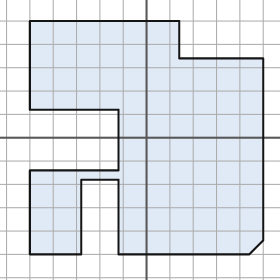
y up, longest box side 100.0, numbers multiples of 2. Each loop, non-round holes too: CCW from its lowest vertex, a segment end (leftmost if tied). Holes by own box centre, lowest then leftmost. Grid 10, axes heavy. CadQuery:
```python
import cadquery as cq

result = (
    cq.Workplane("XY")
    .moveTo(-50.0, -50.0)
    .lineTo(-28.0, -50.0)
    .lineTo(-28.0, -18.0)
    .lineTo(-12.0, -18.0)
    .lineTo(-12.0, -50.0)
    .lineTo(44.0, -50.0)
    .lineTo(50.0, -44.0)
    .lineTo(50.0, 34.0)
    .lineTo(14.0, 34.0)
    .lineTo(14.0, 50.0)
    .lineTo(-50.0, 50.0)
    .lineTo(-50.0, 12.0)
    .lineTo(-12.0, 12.0)
    .lineTo(-12.0, -14.0)
    .lineTo(-50.0, -14.0)
    .close()
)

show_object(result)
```